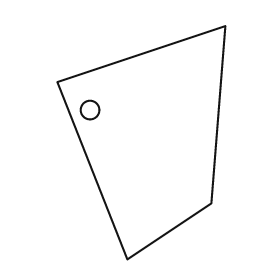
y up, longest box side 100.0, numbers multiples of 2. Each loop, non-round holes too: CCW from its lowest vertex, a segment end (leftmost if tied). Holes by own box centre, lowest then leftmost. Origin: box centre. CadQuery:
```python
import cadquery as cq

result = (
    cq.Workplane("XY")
    .moveTo(-6.0, -50.0)
    .lineTo(30.0, -26.0)
    .lineTo(36.0, 50.0)
    .lineTo(-36.0, 26.0)
    .close()
    .moveTo(-22.0, 14.0)
    .circle(4.0)
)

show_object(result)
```